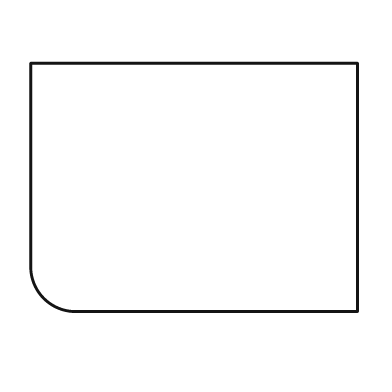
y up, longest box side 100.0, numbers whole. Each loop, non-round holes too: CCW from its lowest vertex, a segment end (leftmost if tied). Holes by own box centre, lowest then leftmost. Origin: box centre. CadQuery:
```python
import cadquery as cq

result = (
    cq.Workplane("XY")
    .moveTo(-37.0, -38.0)
    .lineTo(50.0, -38.0)
    .lineTo(50.0, 38.0)
    .lineTo(-50.0, 38.0)
    .lineTo(-50.0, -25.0)
    .threePointArc((-46.0, -34.0), (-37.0, -38.0))
    .close()
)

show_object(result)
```